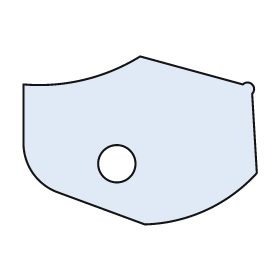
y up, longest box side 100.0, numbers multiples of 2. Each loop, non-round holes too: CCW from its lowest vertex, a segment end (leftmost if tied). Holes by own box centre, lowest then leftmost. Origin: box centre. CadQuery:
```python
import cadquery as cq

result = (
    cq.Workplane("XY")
    .moveTo(2.0, -36.0)
    .threePointArc((28.0, -30.0), (50.0, -14.0))
    .lineTo(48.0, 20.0)
    .threePointArc((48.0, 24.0), (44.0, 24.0))
    .lineTo(0.0, 36.0)
    .threePointArc((-24.0, 26.0), (-50.0, 24.0))
    .lineTo(-50.0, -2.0)
    .threePointArc((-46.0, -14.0), (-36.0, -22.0))
    .close()
    .moveTo(-10.0, -10.0)
    .circle(8.0)
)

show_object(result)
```